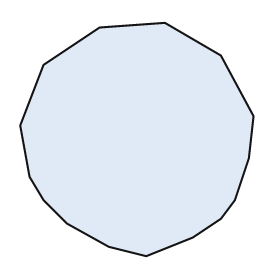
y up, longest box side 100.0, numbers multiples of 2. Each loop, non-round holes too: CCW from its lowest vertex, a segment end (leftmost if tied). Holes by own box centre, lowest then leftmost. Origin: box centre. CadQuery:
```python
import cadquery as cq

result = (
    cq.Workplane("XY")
    .moveTo(4.0, -50.0)
    .lineTo(24.0, -42.0)
    .lineTo(36.0, -34.0)
    .lineTo(42.0, -26.0)
    .lineTo(48.0, -8.0)
    .lineTo(50.0, 10.0)
    .lineTo(36.0, 36.0)
    .lineTo(12.0, 50.0)
    .lineTo(-16.0, 48.0)
    .lineTo(-40.0, 32.0)
    .lineTo(-50.0, 6.0)
    .lineTo(-46.0, -16.0)
    .lineTo(-40.0, -26.0)
    .lineTo(-30.0, -36.0)
    .lineTo(-12.0, -46.0)
    .close()
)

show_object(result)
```